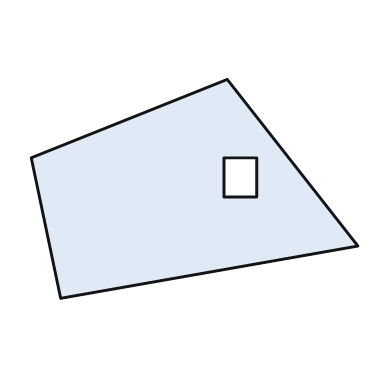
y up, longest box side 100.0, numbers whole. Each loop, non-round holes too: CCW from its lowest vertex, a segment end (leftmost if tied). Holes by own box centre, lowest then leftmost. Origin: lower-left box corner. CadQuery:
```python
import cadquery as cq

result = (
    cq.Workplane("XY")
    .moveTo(9.0, 0.0)
    .lineTo(100.0, 16.0)
    .lineTo(60.0, 67.0)
    .lineTo(0.0, 43.0)
    .close()
    .moveTo(59.0, 31.0)
    .lineTo(69.0, 31.0)
    .lineTo(69.0, 43.0)
    .lineTo(59.0, 43.0)
    .close()
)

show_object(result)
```